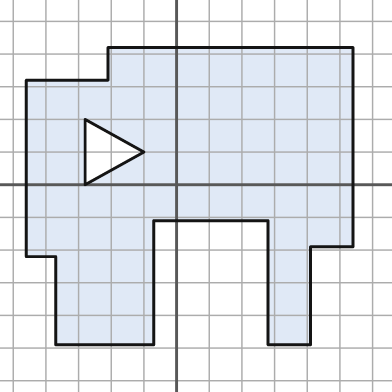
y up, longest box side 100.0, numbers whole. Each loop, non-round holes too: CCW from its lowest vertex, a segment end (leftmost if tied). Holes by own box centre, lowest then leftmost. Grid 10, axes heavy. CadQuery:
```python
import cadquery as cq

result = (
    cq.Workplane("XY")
    .moveTo(-37.0, -49.0)
    .lineTo(-7.0, -49.0)
    .lineTo(-7.0, -11.0)
    .lineTo(28.0, -11.0)
    .lineTo(28.0, -49.0)
    .lineTo(41.0, -49.0)
    .lineTo(41.0, -19.0)
    .lineTo(54.0, -19.0)
    .lineTo(54.0, 42.0)
    .lineTo(-21.0, 42.0)
    .lineTo(-21.0, 32.0)
    .lineTo(-46.0, 32.0)
    .lineTo(-46.0, -22.0)
    .lineTo(-37.0, -22.0)
    .close()
    .moveTo(-28.0, 0.0)
    .lineTo(-10.0, 10.0)
    .lineTo(-28.0, 20.0)
    .close()
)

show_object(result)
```